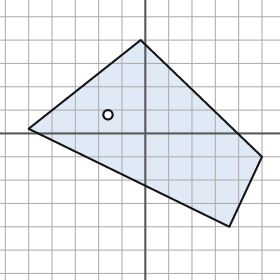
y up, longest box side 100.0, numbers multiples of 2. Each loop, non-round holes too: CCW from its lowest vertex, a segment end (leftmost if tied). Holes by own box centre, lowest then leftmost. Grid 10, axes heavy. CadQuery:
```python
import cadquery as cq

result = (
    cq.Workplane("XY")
    .moveTo(36.0, -40.0)
    .lineTo(50.0, -10.0)
    .lineTo(-2.0, 40.0)
    .lineTo(-50.0, 2.0)
    .close()
    .moveTo(-16.0, 8.0)
    .circle(2.0)
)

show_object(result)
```